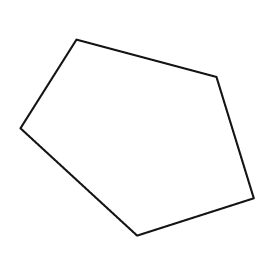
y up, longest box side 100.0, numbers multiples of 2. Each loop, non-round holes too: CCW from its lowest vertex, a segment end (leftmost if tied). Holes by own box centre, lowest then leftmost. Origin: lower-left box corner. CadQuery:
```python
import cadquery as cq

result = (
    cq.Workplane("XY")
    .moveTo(50.0, 0.0)
    .lineTo(100.0, 16.0)
    .lineTo(84.0, 68.0)
    .lineTo(24.0, 84.0)
    .lineTo(0.0, 46.0)
    .close()
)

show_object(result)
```